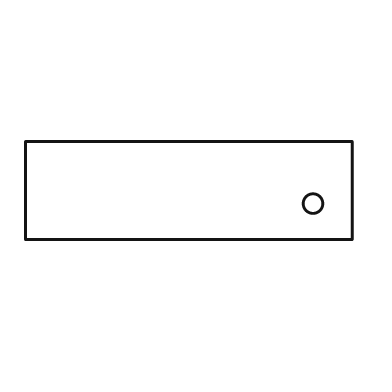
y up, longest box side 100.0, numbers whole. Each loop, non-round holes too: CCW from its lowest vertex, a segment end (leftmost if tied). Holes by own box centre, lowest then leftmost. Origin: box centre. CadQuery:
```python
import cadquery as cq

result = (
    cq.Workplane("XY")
    .moveTo(-50.0, -15.0)
    .lineTo(50.0, -15.0)
    .lineTo(50.0, 15.0)
    .lineTo(-50.0, 15.0)
    .close()
    .moveTo(38.0, -4.0)
    .circle(3.0)
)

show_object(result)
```